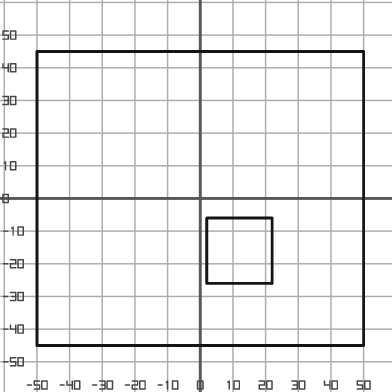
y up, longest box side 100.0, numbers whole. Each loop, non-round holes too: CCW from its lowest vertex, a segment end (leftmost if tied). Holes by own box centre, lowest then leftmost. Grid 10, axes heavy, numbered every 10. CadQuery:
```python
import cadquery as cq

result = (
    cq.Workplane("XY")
    .moveTo(-50.0, -45.0)
    .lineTo(50.0, -45.0)
    .lineTo(50.0, 45.0)
    .lineTo(-50.0, 45.0)
    .close()
    .moveTo(2.0, -26.0)
    .lineTo(22.0, -26.0)
    .lineTo(22.0, -6.0)
    .lineTo(2.0, -6.0)
    .close()
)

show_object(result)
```